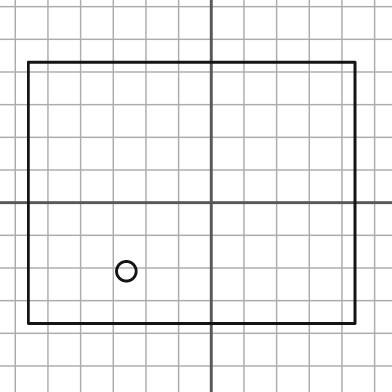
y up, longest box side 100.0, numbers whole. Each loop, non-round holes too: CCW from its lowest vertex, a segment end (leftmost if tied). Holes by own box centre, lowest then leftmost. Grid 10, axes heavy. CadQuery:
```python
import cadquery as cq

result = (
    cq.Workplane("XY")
    .moveTo(-56.0, -37.0)
    .lineTo(44.0, -37.0)
    .lineTo(44.0, 43.0)
    .lineTo(-56.0, 43.0)
    .close()
    .moveTo(-26.0, -21.0)
    .circle(3.0)
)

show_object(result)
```